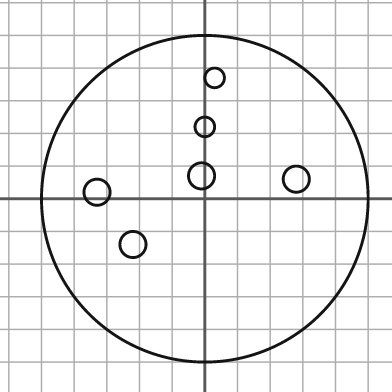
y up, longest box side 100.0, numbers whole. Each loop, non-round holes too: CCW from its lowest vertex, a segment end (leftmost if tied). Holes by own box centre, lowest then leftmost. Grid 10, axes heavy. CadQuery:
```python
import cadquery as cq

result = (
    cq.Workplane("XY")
    .moveTo(0.0, 0.0)
    .circle(50.0)
    .moveTo(-22.0, -14.0)
    .circle(4.0)
    .moveTo(-33.0, 2.0)
    .circle(4.0)
    .moveTo(28.0, 6.0)
    .circle(4.0)
    .moveTo(-1.0, 7.0)
    .circle(4.0)
    .moveTo(0.0, 22.0)
    .circle(3.0)
    .moveTo(3.0, 37.0)
    .circle(3.0)
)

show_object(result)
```